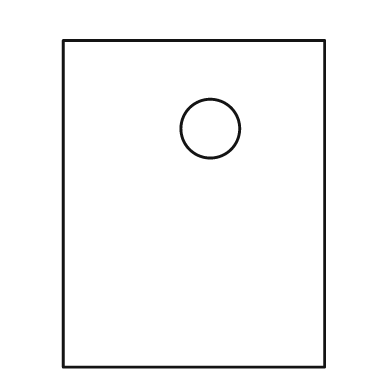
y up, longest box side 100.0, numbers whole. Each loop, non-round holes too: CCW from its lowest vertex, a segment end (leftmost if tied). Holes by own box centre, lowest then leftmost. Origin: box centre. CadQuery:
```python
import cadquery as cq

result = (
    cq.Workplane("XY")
    .moveTo(-40.0, -50.0)
    .lineTo(40.0, -50.0)
    .lineTo(40.0, 50.0)
    .lineTo(-40.0, 50.0)
    .close()
    .moveTo(5.0, 23.0)
    .circle(9.0)
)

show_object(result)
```